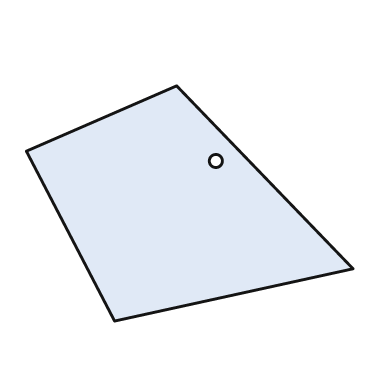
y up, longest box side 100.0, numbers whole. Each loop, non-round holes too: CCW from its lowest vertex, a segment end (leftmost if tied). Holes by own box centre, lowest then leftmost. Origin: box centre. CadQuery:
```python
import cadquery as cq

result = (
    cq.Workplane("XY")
    .moveTo(-23.0, -36.0)
    .lineTo(50.0, -20.0)
    .lineTo(-4.0, 36.0)
    .lineTo(-50.0, 16.0)
    .close()
    .moveTo(8.0, 13.0)
    .circle(2.0)
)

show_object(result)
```